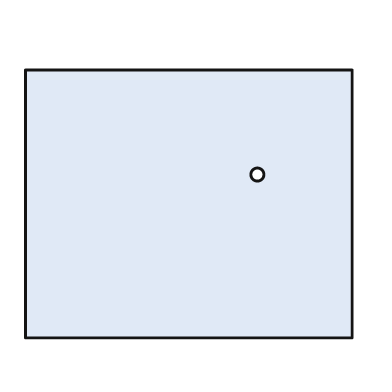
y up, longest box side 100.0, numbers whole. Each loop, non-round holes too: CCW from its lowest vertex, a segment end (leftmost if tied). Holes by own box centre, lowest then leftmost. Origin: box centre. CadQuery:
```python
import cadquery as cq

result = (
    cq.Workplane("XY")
    .moveTo(-50.0, -41.0)
    .lineTo(50.0, -41.0)
    .lineTo(50.0, 41.0)
    .lineTo(-50.0, 41.0)
    .close()
    .moveTo(21.0, 9.0)
    .circle(2.0)
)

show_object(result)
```